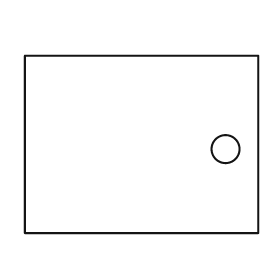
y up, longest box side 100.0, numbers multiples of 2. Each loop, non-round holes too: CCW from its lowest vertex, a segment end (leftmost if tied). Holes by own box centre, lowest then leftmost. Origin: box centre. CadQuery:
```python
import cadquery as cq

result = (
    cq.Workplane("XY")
    .moveTo(-50.0, -38.0)
    .lineTo(50.0, -38.0)
    .lineTo(50.0, 38.0)
    .lineTo(-50.0, 38.0)
    .close()
    .moveTo(36.0, -2.0)
    .circle(6.0)
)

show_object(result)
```